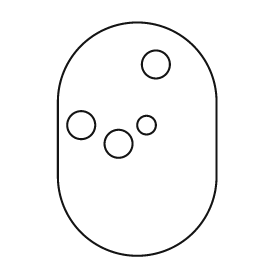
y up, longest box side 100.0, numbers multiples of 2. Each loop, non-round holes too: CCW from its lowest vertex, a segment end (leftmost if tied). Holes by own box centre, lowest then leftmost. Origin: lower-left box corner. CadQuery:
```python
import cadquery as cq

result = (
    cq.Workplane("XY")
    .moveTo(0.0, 34.0)
    .threePointArc((34.0, 0.0), (68.0, 34.0))
    .lineTo(68.0, 66.0)
    .threePointArc((34.0, 100.0), (0.0, 66.0))
    .close()
    .moveTo(26.0, 48.0)
    .circle(6.0)
    .moveTo(10.0, 56.0)
    .circle(6.0)
    .moveTo(38.0, 56.0)
    .circle(4.0)
    .moveTo(42.0, 82.0)
    .circle(6.0)
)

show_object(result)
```